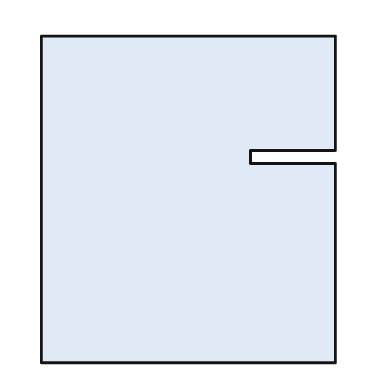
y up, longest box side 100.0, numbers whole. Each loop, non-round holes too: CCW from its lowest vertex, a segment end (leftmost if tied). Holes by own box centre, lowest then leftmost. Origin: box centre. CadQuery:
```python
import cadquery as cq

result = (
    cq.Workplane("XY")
    .moveTo(-45.0, -50.0)
    .lineTo(45.0, -50.0)
    .lineTo(45.0, 11.0)
    .lineTo(19.0, 11.0)
    .lineTo(19.0, 15.0)
    .lineTo(45.0, 15.0)
    .lineTo(45.0, 50.0)
    .lineTo(-45.0, 50.0)
    .close()
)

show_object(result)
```